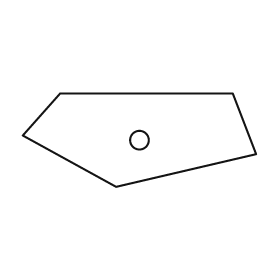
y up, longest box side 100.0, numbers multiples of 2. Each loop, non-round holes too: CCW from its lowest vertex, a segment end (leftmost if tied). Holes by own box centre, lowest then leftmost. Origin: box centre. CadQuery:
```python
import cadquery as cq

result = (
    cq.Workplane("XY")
    .moveTo(-10.0, -20.0)
    .lineTo(50.0, -6.0)
    .lineTo(40.0, 20.0)
    .lineTo(-34.0, 20.0)
    .lineTo(-50.0, 2.0)
    .close()
    .moveTo(0.0, 0.0)
    .circle(4.0)
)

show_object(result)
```